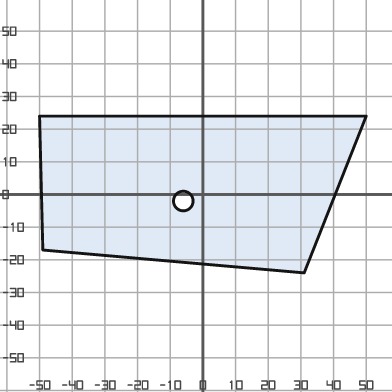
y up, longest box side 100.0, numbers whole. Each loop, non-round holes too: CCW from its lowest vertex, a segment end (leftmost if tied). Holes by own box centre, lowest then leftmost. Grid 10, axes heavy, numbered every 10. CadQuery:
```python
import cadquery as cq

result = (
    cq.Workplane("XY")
    .moveTo(31.0, -24.0)
    .lineTo(50.0, 24.0)
    .lineTo(-50.0, 24.0)
    .lineTo(-49.0, -17.0)
    .close()
    .moveTo(-6.0, -2.0)
    .circle(3.0)
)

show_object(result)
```